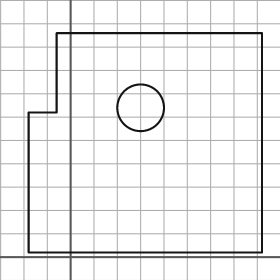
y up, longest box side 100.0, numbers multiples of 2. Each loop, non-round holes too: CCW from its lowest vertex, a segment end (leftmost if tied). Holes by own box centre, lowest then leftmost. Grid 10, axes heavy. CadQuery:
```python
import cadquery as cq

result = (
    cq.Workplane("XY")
    .moveTo(-18.0, 2.0)
    .lineTo(82.0, 2.0)
    .lineTo(82.0, 96.0)
    .lineTo(-6.0, 96.0)
    .lineTo(-6.0, 62.0)
    .lineTo(-18.0, 62.0)
    .close()
    .moveTo(30.0, 64.0)
    .circle(10.0)
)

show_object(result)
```